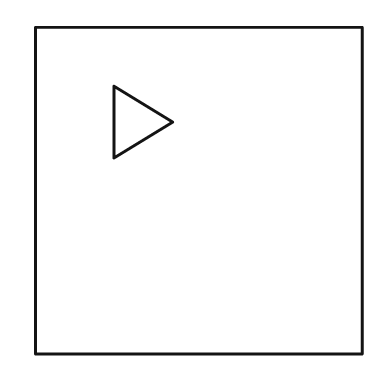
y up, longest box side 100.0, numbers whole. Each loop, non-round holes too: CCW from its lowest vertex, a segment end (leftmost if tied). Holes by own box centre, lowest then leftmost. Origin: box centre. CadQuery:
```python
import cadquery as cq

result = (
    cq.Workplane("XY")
    .moveTo(-50.0, -50.0)
    .lineTo(50.0, -50.0)
    .lineTo(50.0, 50.0)
    .lineTo(-50.0, 50.0)
    .close()
    .moveTo(-26.0, 10.0)
    .lineTo(-8.0, 21.0)
    .lineTo(-26.0, 32.0)
    .close()
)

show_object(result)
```